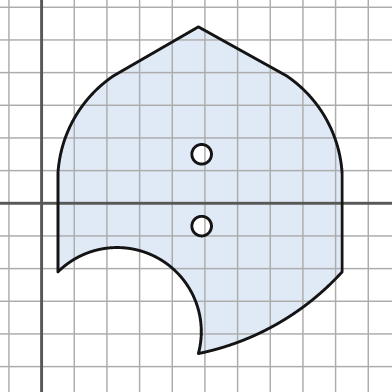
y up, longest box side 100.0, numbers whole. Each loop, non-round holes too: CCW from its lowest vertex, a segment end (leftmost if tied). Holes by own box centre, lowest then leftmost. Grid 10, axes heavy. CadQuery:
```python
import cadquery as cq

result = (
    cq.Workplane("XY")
    .moveTo(48.0, -46.0)
    .threePointArc((72.0, -37.0), (92.0, -21.0))
    .lineTo(92.0, 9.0)
    .threePointArc((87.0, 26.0), (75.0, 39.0))
    .lineTo(48.0, 54.0)
    .lineTo(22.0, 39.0)
    .threePointArc((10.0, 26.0), (5.0, 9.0))
    .lineTo(5.0, -21.0)
    .threePointArc((36.0, -17.0), (48.0, -46.0))
    .close()
    .moveTo(49.0, -7.0)
    .circle(3.0)
    .moveTo(49.0, 15.0)
    .circle(3.0)
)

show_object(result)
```